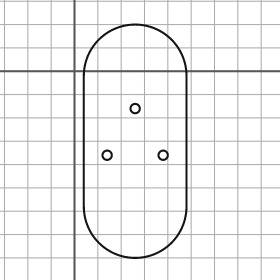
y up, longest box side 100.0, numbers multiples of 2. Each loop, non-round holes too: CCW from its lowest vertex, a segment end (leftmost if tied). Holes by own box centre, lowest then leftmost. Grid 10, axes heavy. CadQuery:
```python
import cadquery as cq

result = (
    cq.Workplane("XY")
    .moveTo(4.0, -58.0)
    .threePointArc((26.0, -80.0), (48.0, -58.0))
    .lineTo(48.0, -2.0)
    .threePointArc((26.0, 20.0), (4.0, -2.0))
    .close()
    .moveTo(14.0, -36.0)
    .circle(2.0)
    .moveTo(38.0, -36.0)
    .circle(2.0)
    .moveTo(26.0, -16.0)
    .circle(2.0)
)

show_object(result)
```